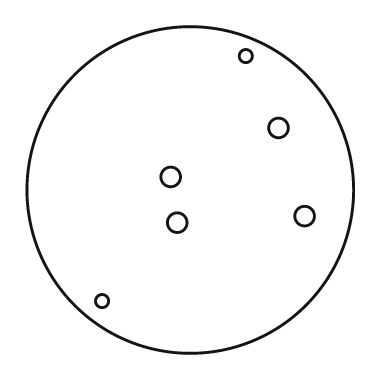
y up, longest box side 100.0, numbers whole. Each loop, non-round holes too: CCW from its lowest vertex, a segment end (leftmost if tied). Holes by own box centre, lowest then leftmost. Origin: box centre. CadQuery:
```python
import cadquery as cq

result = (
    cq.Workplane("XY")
    .moveTo(0.0, 0.0)
    .circle(50.0)
    .moveTo(-27.0, -34.0)
    .circle(2.0)
    .moveTo(-4.0, -10.0)
    .circle(3.0)
    .moveTo(35.0, -8.0)
    .circle(3.0)
    .moveTo(-6.0, 4.0)
    .circle(3.0)
    .moveTo(27.0, 19.0)
    .circle(3.0)
    .moveTo(17.0, 41.0)
    .circle(2.0)
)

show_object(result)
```